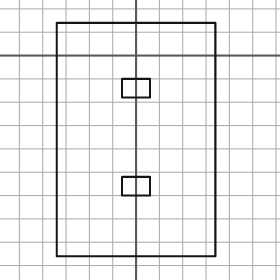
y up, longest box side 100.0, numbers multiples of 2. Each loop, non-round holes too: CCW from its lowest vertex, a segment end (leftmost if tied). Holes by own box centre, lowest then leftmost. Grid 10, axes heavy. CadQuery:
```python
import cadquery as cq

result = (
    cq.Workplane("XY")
    .moveTo(-34.0, -86.0)
    .lineTo(34.0, -86.0)
    .lineTo(34.0, 14.0)
    .lineTo(-34.0, 14.0)
    .close()
    .moveTo(-6.0, -60.0)
    .lineTo(6.0, -60.0)
    .lineTo(6.0, -52.0)
    .lineTo(-6.0, -52.0)
    .close()
    .moveTo(-6.0, -18.0)
    .lineTo(6.0, -18.0)
    .lineTo(6.0, -10.0)
    .lineTo(-6.0, -10.0)
    .close()
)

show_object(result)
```